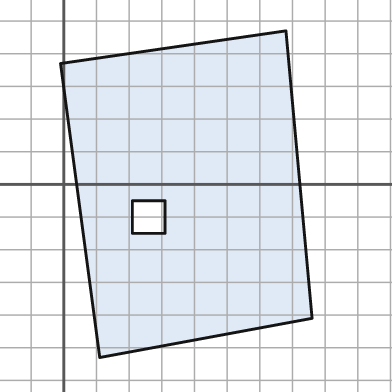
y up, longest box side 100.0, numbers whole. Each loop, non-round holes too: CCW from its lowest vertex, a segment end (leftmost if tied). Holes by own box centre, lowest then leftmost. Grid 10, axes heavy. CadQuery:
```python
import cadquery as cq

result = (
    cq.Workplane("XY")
    .moveTo(11.0, -53.0)
    .lineTo(76.0, -41.0)
    .lineTo(68.0, 47.0)
    .lineTo(-1.0, 37.0)
    .close()
    .moveTo(21.0, -15.0)
    .lineTo(31.0, -15.0)
    .lineTo(31.0, -5.0)
    .lineTo(21.0, -5.0)
    .close()
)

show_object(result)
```